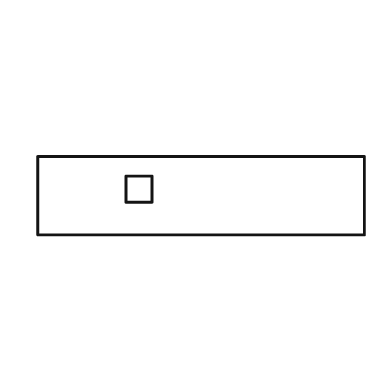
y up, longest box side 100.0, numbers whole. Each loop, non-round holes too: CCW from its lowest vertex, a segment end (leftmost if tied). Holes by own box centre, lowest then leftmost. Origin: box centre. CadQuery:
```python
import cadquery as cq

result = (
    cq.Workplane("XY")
    .moveTo(-50.0, -12.0)
    .lineTo(50.0, -12.0)
    .lineTo(50.0, 12.0)
    .lineTo(-50.0, 12.0)
    .close()
    .moveTo(-23.0, -2.0)
    .lineTo(-15.0, -2.0)
    .lineTo(-15.0, 6.0)
    .lineTo(-23.0, 6.0)
    .close()
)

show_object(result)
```